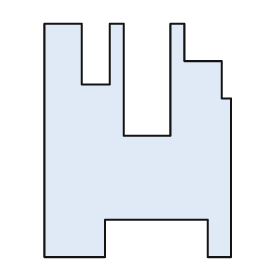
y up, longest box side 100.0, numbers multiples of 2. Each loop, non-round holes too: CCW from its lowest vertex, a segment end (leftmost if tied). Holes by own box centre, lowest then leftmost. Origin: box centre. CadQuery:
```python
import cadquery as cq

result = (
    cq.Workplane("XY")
    .moveTo(-40.0, -50.0)
    .lineTo(-14.0, -50.0)
    .lineTo(-14.0, -34.0)
    .lineTo(30.0, -34.0)
    .lineTo(30.0, -50.0)
    .lineTo(40.0, -50.0)
    .lineTo(40.0, 18.0)
    .lineTo(36.0, 18.0)
    .lineTo(36.0, 34.0)
    .lineTo(20.0, 34.0)
    .lineTo(20.0, 50.0)
    .lineTo(14.0, 50.0)
    .lineTo(14.0, 2.0)
    .lineTo(-6.0, 2.0)
    .lineTo(-6.0, 50.0)
    .lineTo(-12.0, 50.0)
    .lineTo(-12.0, 24.0)
    .lineTo(-24.0, 24.0)
    .lineTo(-24.0, 50.0)
    .lineTo(-40.0, 50.0)
    .close()
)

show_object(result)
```